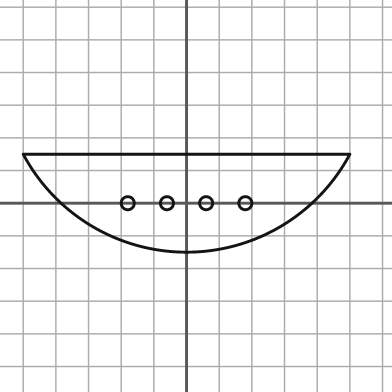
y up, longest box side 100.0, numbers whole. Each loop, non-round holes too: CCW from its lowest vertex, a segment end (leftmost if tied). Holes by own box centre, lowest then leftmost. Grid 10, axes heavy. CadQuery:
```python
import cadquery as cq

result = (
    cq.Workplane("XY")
    .moveTo(-50.0, 15.0)
    .threePointArc((0.0, -15.0), (50.0, 15.0))
    .close()
    .moveTo(-18.0, 0.0)
    .circle(2.0)
    .moveTo(-6.0, 0.0)
    .circle(2.0)
    .moveTo(6.0, 0.0)
    .circle(2.0)
    .moveTo(18.0, 0.0)
    .circle(2.0)
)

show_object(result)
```